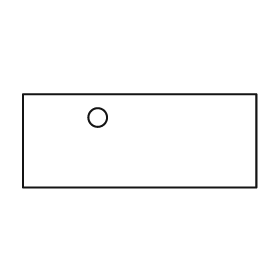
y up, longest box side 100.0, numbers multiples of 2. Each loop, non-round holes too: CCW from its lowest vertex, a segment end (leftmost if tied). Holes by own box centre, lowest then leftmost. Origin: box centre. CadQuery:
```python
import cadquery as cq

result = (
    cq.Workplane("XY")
    .moveTo(-50.0, -20.0)
    .lineTo(50.0, -20.0)
    .lineTo(50.0, 20.0)
    .lineTo(-50.0, 20.0)
    .close()
    .moveTo(-18.0, 10.0)
    .circle(4.0)
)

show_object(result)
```